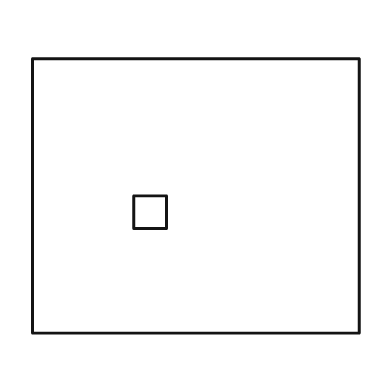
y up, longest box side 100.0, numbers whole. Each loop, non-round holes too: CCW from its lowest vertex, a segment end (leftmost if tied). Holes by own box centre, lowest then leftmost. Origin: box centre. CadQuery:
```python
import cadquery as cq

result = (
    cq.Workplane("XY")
    .moveTo(-50.0, -42.0)
    .lineTo(50.0, -42.0)
    .lineTo(50.0, 42.0)
    .lineTo(-50.0, 42.0)
    .close()
    .moveTo(-19.0, -10.0)
    .lineTo(-9.0, -10.0)
    .lineTo(-9.0, 0.0)
    .lineTo(-19.0, 0.0)
    .close()
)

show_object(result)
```